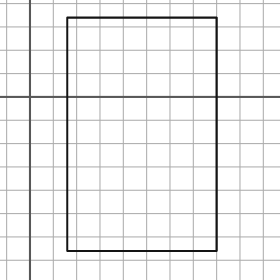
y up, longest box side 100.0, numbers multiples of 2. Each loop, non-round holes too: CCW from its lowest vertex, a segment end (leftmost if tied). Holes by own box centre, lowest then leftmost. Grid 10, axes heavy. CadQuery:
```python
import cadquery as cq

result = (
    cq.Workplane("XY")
    .moveTo(16.0, -66.0)
    .lineTo(80.0, -66.0)
    .lineTo(80.0, 34.0)
    .lineTo(16.0, 34.0)
    .close()
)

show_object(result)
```